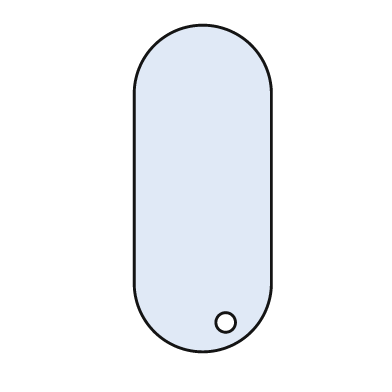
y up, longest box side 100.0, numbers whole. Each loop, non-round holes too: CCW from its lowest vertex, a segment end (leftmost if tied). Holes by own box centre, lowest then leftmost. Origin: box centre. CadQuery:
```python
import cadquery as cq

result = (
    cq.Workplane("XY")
    .moveTo(-21.0, -29.0)
    .threePointArc((0.0, -50.0), (21.0, -29.0))
    .lineTo(21.0, 29.0)
    .threePointArc((0.0, 50.0), (-21.0, 29.0))
    .close()
    .moveTo(7.0, -41.0)
    .circle(3.0)
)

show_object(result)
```